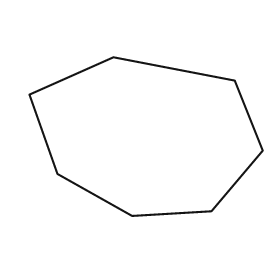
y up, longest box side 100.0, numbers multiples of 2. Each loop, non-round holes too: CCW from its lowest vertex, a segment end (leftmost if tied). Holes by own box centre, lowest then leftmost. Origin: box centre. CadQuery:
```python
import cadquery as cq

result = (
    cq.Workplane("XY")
    .moveTo(-6.0, -34.0)
    .lineTo(28.0, -32.0)
    .lineTo(50.0, -6.0)
    .lineTo(38.0, 24.0)
    .lineTo(-14.0, 34.0)
    .lineTo(-50.0, 18.0)
    .lineTo(-38.0, -16.0)
    .close()
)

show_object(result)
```